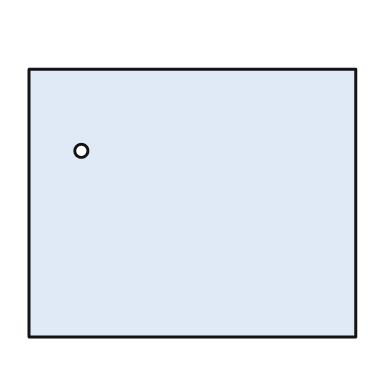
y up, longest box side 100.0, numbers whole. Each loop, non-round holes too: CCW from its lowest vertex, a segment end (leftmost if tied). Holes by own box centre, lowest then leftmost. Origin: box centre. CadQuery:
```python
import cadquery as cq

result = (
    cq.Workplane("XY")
    .moveTo(-50.0, -41.0)
    .lineTo(50.0, -41.0)
    .lineTo(50.0, 41.0)
    .lineTo(-50.0, 41.0)
    .close()
    .moveTo(-34.0, 16.0)
    .circle(2.0)
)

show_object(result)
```